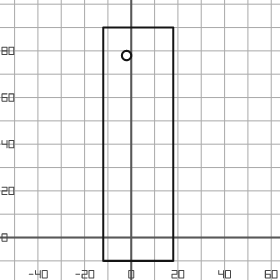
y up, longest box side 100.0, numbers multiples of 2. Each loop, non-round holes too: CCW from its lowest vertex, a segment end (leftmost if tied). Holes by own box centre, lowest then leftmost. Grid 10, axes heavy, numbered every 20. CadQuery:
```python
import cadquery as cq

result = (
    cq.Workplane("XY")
    .moveTo(-12.0, -10.0)
    .lineTo(18.0, -10.0)
    .lineTo(18.0, 90.0)
    .lineTo(-12.0, 90.0)
    .close()
    .moveTo(-2.0, 78.0)
    .circle(2.0)
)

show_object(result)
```